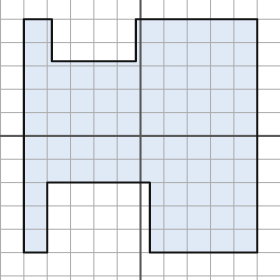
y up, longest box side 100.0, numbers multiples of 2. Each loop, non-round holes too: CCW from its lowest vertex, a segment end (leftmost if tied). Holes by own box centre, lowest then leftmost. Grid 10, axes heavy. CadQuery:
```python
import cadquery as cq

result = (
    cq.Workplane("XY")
    .moveTo(-50.0, -50.0)
    .lineTo(-40.0, -50.0)
    .lineTo(-40.0, -20.0)
    .lineTo(4.0, -20.0)
    .lineTo(4.0, -50.0)
    .lineTo(50.0, -50.0)
    .lineTo(50.0, 50.0)
    .lineTo(-2.0, 50.0)
    .lineTo(-2.0, 32.0)
    .lineTo(-38.0, 32.0)
    .lineTo(-38.0, 50.0)
    .lineTo(-50.0, 50.0)
    .close()
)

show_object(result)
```